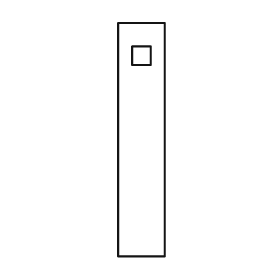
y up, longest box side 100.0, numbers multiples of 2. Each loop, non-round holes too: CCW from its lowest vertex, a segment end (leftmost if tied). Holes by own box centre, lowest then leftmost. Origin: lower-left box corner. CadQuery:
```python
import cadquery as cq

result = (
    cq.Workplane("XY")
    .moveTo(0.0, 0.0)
    .lineTo(20.0, 0.0)
    .lineTo(20.0, 100.0)
    .lineTo(0.0, 100.0)
    .close()
    .moveTo(6.0, 82.0)
    .lineTo(14.0, 82.0)
    .lineTo(14.0, 90.0)
    .lineTo(6.0, 90.0)
    .close()
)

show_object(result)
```